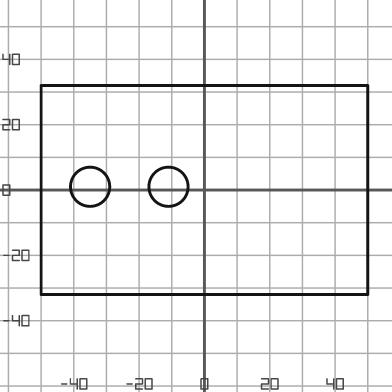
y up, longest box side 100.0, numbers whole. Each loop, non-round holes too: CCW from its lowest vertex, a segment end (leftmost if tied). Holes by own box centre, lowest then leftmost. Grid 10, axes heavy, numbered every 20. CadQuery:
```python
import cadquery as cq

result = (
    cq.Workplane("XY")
    .moveTo(-50.0, -32.0)
    .lineTo(50.0, -32.0)
    .lineTo(50.0, 32.0)
    .lineTo(-50.0, 32.0)
    .close()
    .moveTo(-35.0, 1.0)
    .circle(6.0)
    .moveTo(-11.0, 1.0)
    .circle(6.0)
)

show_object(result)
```